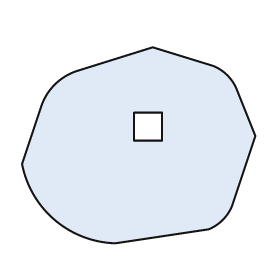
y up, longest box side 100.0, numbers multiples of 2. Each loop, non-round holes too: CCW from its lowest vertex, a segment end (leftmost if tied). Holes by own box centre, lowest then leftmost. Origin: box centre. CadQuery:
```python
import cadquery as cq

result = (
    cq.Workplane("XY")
    .moveTo(-10.0, -42.0)
    .lineTo(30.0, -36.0)
    .threePointArc((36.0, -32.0), (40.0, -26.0))
    .lineTo(50.0, 4.0)
    .lineTo(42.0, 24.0)
    .threePointArc((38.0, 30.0), (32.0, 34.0))
    .lineTo(6.0, 42.0)
    .lineTo(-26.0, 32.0)
    .threePointArc((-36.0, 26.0), (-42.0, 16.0))
    .lineTo(-50.0, -8.0)
    .threePointArc((-36.0, -32.0), (-10.0, -42.0))
    .close()
    .moveTo(-2.0, 2.0)
    .lineTo(10.0, 2.0)
    .lineTo(10.0, 14.0)
    .lineTo(-2.0, 14.0)
    .close()
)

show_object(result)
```